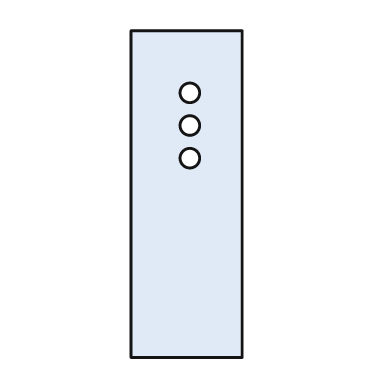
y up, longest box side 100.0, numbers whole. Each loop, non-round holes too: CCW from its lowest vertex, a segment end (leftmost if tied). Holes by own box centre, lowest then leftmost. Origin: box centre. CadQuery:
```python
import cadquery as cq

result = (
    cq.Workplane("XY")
    .moveTo(-17.0, -50.0)
    .lineTo(17.0, -50.0)
    .lineTo(17.0, 50.0)
    .lineTo(-17.0, 50.0)
    .close()
    .moveTo(1.0, 11.0)
    .circle(3.0)
    .moveTo(1.0, 21.0)
    .circle(3.0)
    .moveTo(1.0, 31.0)
    .circle(3.0)
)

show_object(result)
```